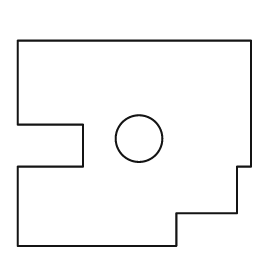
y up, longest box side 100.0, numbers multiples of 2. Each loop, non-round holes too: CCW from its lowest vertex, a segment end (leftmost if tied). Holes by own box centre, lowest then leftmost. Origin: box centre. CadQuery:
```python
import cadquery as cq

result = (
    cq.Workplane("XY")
    .moveTo(-50.0, -44.0)
    .lineTo(18.0, -44.0)
    .lineTo(18.0, -30.0)
    .lineTo(44.0, -30.0)
    .lineTo(44.0, -10.0)
    .lineTo(50.0, -10.0)
    .lineTo(50.0, 44.0)
    .lineTo(-50.0, 44.0)
    .lineTo(-50.0, 8.0)
    .lineTo(-22.0, 8.0)
    .lineTo(-22.0, -10.0)
    .lineTo(-50.0, -10.0)
    .close()
    .moveTo(2.0, 2.0)
    .circle(10.0)
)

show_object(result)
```